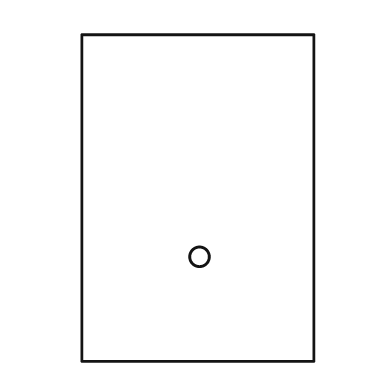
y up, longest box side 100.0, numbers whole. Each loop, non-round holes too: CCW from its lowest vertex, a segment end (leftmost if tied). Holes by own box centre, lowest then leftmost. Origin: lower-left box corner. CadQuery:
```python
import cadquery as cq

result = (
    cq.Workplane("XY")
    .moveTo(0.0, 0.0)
    .lineTo(71.0, 0.0)
    .lineTo(71.0, 100.0)
    .lineTo(0.0, 100.0)
    .close()
    .moveTo(36.0, 32.0)
    .circle(3.0)
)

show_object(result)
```